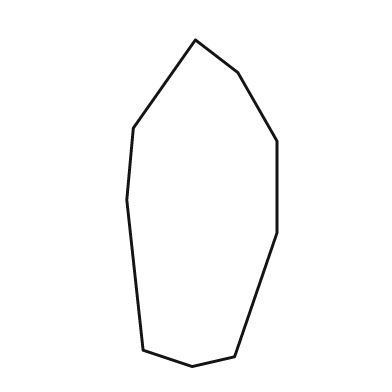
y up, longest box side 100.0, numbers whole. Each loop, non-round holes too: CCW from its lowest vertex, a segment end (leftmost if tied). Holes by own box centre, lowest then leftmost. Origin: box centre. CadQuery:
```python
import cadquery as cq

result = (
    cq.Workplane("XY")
    .moveTo(-3.0, -50.0)
    .lineTo(10.0, -47.0)
    .lineTo(23.0, -9.0)
    .lineTo(23.0, 19.0)
    .lineTo(11.0, 40.0)
    .lineTo(-2.0, 50.0)
    .lineTo(-21.0, 23.0)
    .lineTo(-23.0, 1.0)
    .lineTo(-18.0, -45.0)
    .close()
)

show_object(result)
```